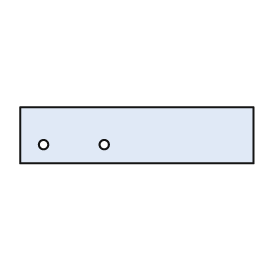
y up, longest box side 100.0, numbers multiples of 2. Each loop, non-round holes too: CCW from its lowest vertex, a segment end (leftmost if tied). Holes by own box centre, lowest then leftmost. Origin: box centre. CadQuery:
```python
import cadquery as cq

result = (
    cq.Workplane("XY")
    .moveTo(-50.0, -12.0)
    .lineTo(50.0, -12.0)
    .lineTo(50.0, 12.0)
    .lineTo(-50.0, 12.0)
    .close()
    .moveTo(-40.0, -4.0)
    .circle(2.0)
    .moveTo(-14.0, -4.0)
    .circle(2.0)
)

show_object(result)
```